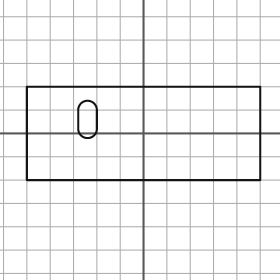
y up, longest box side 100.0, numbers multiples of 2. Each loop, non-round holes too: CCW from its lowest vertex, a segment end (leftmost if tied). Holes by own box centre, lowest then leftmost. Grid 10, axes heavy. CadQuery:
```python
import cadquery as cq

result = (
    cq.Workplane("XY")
    .moveTo(-50.0, -20.0)
    .lineTo(50.0, -20.0)
    .lineTo(50.0, 20.0)
    .lineTo(-50.0, 20.0)
    .close()
    .moveTo(-28.0, 2.0)
    .threePointArc((-24.0, -2.0), (-20.0, 2.0))
    .lineTo(-20.0, 10.0)
    .threePointArc((-24.0, 14.0), (-28.0, 10.0))
    .close()
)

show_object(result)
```